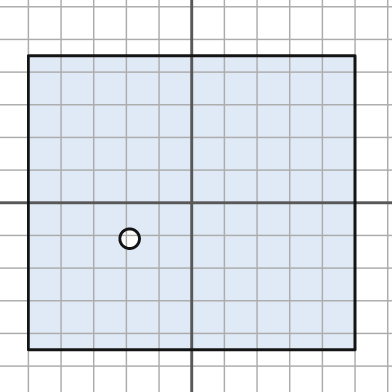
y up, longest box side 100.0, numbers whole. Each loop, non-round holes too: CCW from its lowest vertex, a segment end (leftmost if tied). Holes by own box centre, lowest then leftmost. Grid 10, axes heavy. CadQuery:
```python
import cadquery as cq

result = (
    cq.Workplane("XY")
    .moveTo(-50.0, -45.0)
    .lineTo(50.0, -45.0)
    .lineTo(50.0, 45.0)
    .lineTo(-50.0, 45.0)
    .close()
    .moveTo(-19.0, -11.0)
    .circle(3.0)
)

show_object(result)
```